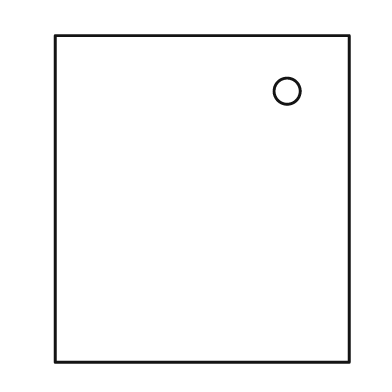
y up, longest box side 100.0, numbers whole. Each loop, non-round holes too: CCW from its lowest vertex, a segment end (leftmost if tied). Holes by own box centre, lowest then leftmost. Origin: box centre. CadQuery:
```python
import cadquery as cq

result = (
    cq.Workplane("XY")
    .moveTo(-45.0, -50.0)
    .lineTo(45.0, -50.0)
    .lineTo(45.0, 50.0)
    .lineTo(-45.0, 50.0)
    .close()
    .moveTo(26.0, 33.0)
    .circle(4.0)
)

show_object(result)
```